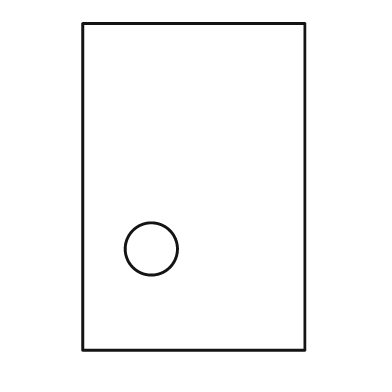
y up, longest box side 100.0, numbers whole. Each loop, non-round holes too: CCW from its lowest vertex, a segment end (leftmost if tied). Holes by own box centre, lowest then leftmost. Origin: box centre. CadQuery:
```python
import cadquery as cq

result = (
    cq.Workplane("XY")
    .moveTo(-34.0, -50.0)
    .lineTo(34.0, -50.0)
    .lineTo(34.0, 50.0)
    .lineTo(-34.0, 50.0)
    .close()
    .moveTo(-13.0, -19.0)
    .circle(8.0)
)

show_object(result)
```